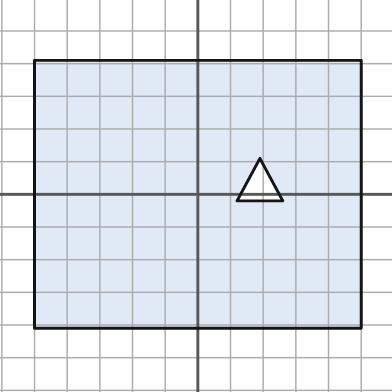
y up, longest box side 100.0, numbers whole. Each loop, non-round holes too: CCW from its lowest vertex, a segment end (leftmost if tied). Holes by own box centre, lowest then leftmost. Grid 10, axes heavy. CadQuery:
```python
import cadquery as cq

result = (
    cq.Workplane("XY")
    .moveTo(-50.0, -41.0)
    .lineTo(50.0, -41.0)
    .lineTo(50.0, 41.0)
    .lineTo(-50.0, 41.0)
    .close()
    .moveTo(12.0, -2.0)
    .lineTo(26.0, -2.0)
    .lineTo(19.0, 11.0)
    .close()
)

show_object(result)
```